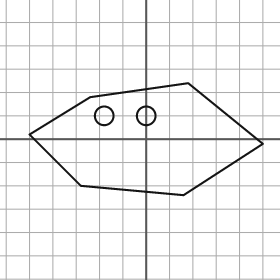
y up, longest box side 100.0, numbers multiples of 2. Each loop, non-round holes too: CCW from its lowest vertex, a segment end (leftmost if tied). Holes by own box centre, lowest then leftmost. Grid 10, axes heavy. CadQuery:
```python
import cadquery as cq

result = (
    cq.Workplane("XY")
    .moveTo(16.0, -24.0)
    .lineTo(50.0, -2.0)
    .lineTo(18.0, 24.0)
    .lineTo(-24.0, 18.0)
    .lineTo(-50.0, 2.0)
    .lineTo(-28.0, -20.0)
    .close()
    .moveTo(-18.0, 10.0)
    .circle(4.0)
    .moveTo(0.0, 10.0)
    .circle(4.0)
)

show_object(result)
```